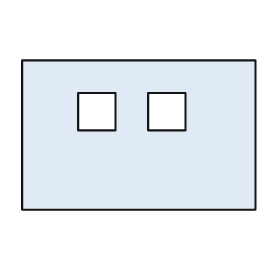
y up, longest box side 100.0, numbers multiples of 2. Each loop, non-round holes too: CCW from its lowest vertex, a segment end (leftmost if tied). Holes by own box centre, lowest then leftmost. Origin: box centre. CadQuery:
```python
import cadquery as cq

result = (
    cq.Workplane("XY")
    .moveTo(-50.0, -32.0)
    .lineTo(50.0, -32.0)
    .lineTo(50.0, 32.0)
    .lineTo(-50.0, 32.0)
    .close()
    .moveTo(-26.0, 2.0)
    .lineTo(-10.0, 2.0)
    .lineTo(-10.0, 18.0)
    .lineTo(-26.0, 18.0)
    .close()
    .moveTo(4.0, 2.0)
    .lineTo(20.0, 2.0)
    .lineTo(20.0, 18.0)
    .lineTo(4.0, 18.0)
    .close()
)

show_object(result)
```